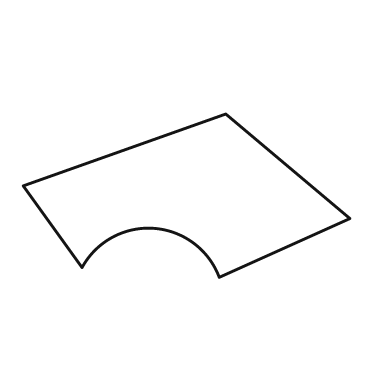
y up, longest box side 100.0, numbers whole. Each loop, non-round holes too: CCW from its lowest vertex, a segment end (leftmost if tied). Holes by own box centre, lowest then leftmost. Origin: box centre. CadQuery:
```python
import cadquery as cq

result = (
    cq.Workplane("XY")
    .moveTo(10.0, -25.0)
    .lineTo(50.0, -7.0)
    .lineTo(12.0, 25.0)
    .lineTo(-50.0, 3.0)
    .lineTo(-32.0, -22.0)
    .threePointArc((-10.0, -10.0), (10.0, -25.0))
    .close()
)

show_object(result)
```